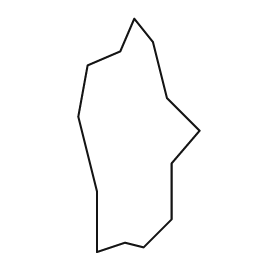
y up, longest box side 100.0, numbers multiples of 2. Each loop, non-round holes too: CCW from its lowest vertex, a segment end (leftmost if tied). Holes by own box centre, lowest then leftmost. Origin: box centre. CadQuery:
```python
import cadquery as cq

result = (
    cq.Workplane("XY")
    .moveTo(-18.0, -50.0)
    .lineTo(-6.0, -46.0)
    .lineTo(2.0, -48.0)
    .lineTo(14.0, -36.0)
    .lineTo(14.0, -12.0)
    .lineTo(26.0, 2.0)
    .lineTo(12.0, 16.0)
    .lineTo(6.0, 40.0)
    .lineTo(-2.0, 50.0)
    .lineTo(-8.0, 36.0)
    .lineTo(-22.0, 30.0)
    .lineTo(-26.0, 8.0)
    .lineTo(-18.0, -24.0)
    .close()
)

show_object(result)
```